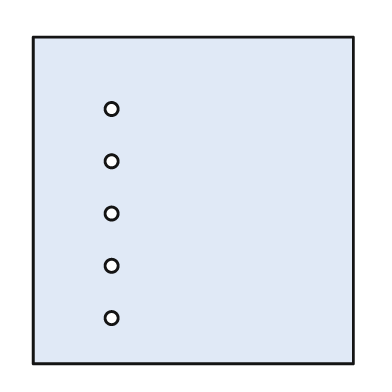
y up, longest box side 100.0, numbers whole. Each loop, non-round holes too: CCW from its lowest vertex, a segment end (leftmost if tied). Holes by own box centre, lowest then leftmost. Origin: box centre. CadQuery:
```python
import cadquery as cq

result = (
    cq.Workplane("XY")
    .moveTo(-49.0, -50.0)
    .lineTo(49.0, -50.0)
    .lineTo(49.0, 50.0)
    .lineTo(-49.0, 50.0)
    .close()
    .moveTo(-25.0, -36.0)
    .circle(2.0)
    .moveTo(-25.0, -20.0)
    .circle(2.0)
    .moveTo(-25.0, -4.0)
    .circle(2.0)
    .moveTo(-25.0, 12.0)
    .circle(2.0)
    .moveTo(-25.0, 28.0)
    .circle(2.0)
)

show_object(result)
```